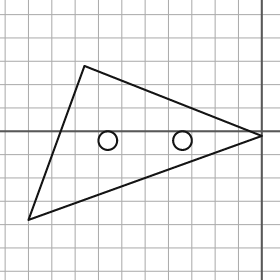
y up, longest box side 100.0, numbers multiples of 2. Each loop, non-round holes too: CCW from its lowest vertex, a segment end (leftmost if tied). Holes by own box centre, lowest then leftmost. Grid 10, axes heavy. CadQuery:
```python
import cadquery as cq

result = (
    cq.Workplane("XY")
    .moveTo(-100.0, -38.0)
    .lineTo(0.0, -2.0)
    .lineTo(-76.0, 28.0)
    .close()
    .moveTo(-66.0, -4.0)
    .circle(4.0)
    .moveTo(-34.0, -4.0)
    .circle(4.0)
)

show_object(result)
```